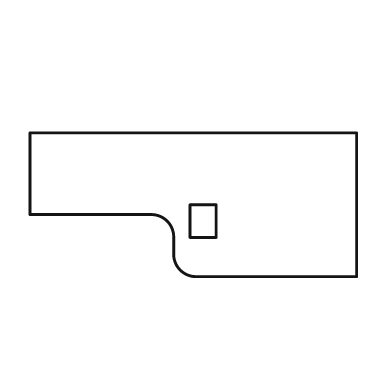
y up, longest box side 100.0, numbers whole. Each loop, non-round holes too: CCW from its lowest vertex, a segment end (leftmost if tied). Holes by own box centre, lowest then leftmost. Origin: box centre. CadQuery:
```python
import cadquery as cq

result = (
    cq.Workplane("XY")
    .moveTo(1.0, -22.0)
    .lineTo(50.0, -22.0)
    .lineTo(50.0, 22.0)
    .lineTo(-50.0, 22.0)
    .lineTo(-50.0, -3.0)
    .lineTo(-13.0, -3.0)
    .threePointArc((-8.0, -5.0), (-6.0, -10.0))
    .lineTo(-6.0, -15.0)
    .threePointArc((-4.0, -20.0), (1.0, -22.0))
    .close()
    .moveTo(-1.0, -10.0)
    .lineTo(7.0, -10.0)
    .lineTo(7.0, 0.0)
    .lineTo(-1.0, 0.0)
    .close()
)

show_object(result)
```